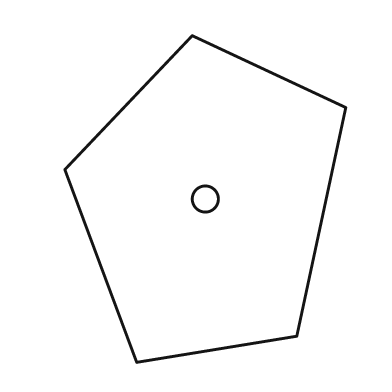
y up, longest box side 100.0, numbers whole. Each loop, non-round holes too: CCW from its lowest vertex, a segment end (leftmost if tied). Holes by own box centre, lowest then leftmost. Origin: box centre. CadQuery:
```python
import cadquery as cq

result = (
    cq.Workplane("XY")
    .moveTo(-21.0, -50.0)
    .lineTo(28.0, -42.0)
    .lineTo(43.0, 28.0)
    .lineTo(-4.0, 50.0)
    .lineTo(-43.0, 9.0)
    .close()
    .moveTo(0.0, 0.0)
    .circle(4.0)
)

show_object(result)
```